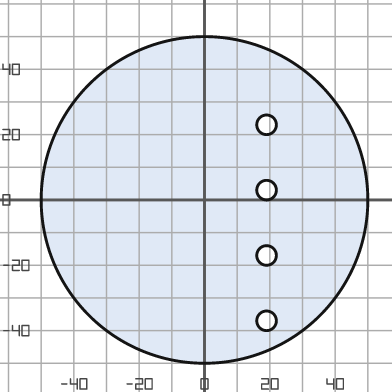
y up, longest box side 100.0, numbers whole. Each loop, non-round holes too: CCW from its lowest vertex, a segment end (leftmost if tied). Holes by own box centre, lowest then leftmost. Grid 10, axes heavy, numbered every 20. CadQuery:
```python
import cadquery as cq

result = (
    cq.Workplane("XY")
    .moveTo(0.0, 0.0)
    .circle(50.0)
    .moveTo(19.0, -37.0)
    .circle(3.0)
    .moveTo(19.0, -17.0)
    .circle(3.0)
    .moveTo(19.0, 3.0)
    .circle(3.0)
    .moveTo(19.0, 23.0)
    .circle(3.0)
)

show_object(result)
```